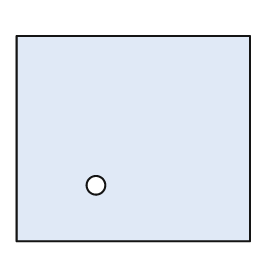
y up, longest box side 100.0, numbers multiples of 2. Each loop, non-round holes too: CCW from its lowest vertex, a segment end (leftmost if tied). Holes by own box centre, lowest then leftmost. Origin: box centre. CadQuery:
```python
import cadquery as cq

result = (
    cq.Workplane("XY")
    .moveTo(-50.0, -44.0)
    .lineTo(50.0, -44.0)
    .lineTo(50.0, 44.0)
    .lineTo(-50.0, 44.0)
    .close()
    .moveTo(-16.0, -20.0)
    .circle(4.0)
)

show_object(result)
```